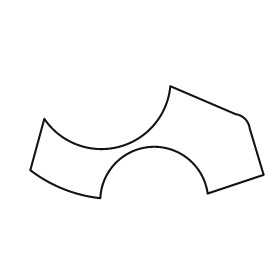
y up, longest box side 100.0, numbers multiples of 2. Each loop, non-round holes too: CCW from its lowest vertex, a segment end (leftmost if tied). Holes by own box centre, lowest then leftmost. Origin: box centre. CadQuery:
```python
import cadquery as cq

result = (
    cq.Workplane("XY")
    .moveTo(-20.0, -24.0)
    .threePointArc((2.0, -2.0), (26.0, -22.0))
    .lineTo(50.0, -14.0)
    .lineTo(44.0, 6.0)
    .threePointArc((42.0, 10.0), (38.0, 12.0))
    .lineTo(10.0, 24.0)
    .threePointArc((-12.0, -2.0), (-44.0, 10.0))
    .lineTo(-50.0, -12.0)
    .threePointArc((-36.0, -20.0), (-20.0, -24.0))
    .close()
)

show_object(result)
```